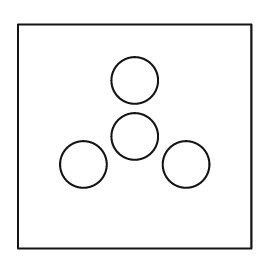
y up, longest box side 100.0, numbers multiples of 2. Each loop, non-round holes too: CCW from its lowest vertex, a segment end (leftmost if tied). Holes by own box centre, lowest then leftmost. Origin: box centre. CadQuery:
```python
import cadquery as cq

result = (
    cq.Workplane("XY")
    .moveTo(-50.0, -48.0)
    .lineTo(50.0, -48.0)
    .lineTo(50.0, 48.0)
    .lineTo(-50.0, 48.0)
    .close()
    .moveTo(-22.0, -12.0)
    .circle(10.0)
    .moveTo(22.0, -12.0)
    .circle(10.0)
    .moveTo(0.0, 0.0)
    .circle(10.0)
    .moveTo(0.0, 24.0)
    .circle(10.0)
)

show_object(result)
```